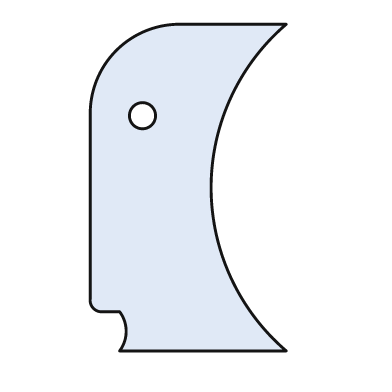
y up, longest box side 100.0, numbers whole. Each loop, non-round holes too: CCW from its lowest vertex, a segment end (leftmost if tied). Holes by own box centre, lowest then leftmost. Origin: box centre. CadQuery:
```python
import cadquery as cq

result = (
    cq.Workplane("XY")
    .moveTo(-21.0, -50.0)
    .lineTo(30.0, -50.0)
    .threePointArc((7.0, 0.0), (30.0, 50.0))
    .lineTo(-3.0, 50.0)
    .threePointArc((-22.0, 42.0), (-30.0, 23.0))
    .lineTo(-30.0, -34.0)
    .threePointArc((-29.0, -37.0), (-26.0, -38.0))
    .lineTo(-21.0, -38.0)
    .threePointArc((-19.0, -44.0), (-21.0, -50.0))
    .close()
    .moveTo(-14.0, 22.0)
    .circle(4.0)
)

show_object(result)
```